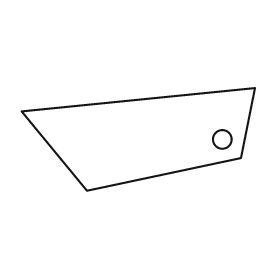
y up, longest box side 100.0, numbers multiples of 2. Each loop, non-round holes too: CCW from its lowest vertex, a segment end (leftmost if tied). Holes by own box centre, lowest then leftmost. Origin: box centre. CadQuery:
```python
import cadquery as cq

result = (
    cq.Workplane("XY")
    .moveTo(-22.0, -22.0)
    .lineTo(44.0, -8.0)
    .lineTo(50.0, 22.0)
    .lineTo(-50.0, 12.0)
    .close()
    .moveTo(36.0, 0.0)
    .circle(4.0)
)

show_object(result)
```